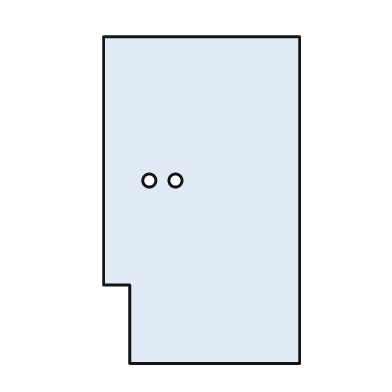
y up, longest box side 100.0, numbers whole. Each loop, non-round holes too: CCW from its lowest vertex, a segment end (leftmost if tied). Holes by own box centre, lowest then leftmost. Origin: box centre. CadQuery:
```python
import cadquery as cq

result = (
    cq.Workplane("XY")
    .moveTo(-22.0, -50.0)
    .lineTo(30.0, -50.0)
    .lineTo(30.0, 50.0)
    .lineTo(-30.0, 50.0)
    .lineTo(-30.0, -26.0)
    .lineTo(-22.0, -26.0)
    .close()
    .moveTo(-16.0, 6.0)
    .circle(2.0)
    .moveTo(-8.0, 6.0)
    .circle(2.0)
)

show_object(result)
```